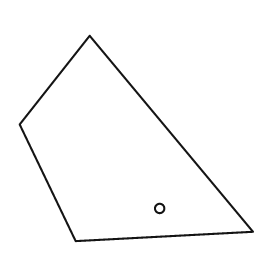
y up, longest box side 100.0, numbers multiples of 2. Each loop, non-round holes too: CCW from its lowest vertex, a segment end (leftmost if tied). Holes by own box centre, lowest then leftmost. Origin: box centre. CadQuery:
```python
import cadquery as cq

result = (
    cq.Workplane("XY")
    .moveTo(-26.0, -44.0)
    .lineTo(50.0, -40.0)
    .lineTo(-20.0, 44.0)
    .lineTo(-50.0, 6.0)
    .close()
    .moveTo(10.0, -30.0)
    .circle(2.0)
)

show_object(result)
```